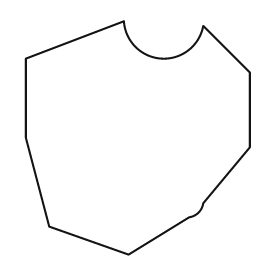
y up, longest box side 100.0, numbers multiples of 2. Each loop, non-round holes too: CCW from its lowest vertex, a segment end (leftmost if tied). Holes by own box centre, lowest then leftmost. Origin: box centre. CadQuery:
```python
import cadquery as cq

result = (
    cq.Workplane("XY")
    .moveTo(-4.0, -50.0)
    .lineTo(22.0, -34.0)
    .threePointArc((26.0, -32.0), (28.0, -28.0))
    .lineTo(48.0, -4.0)
    .lineTo(48.0, 28.0)
    .lineTo(28.0, 48.0)
    .threePointArc((10.0, 34.0), (-6.0, 50.0))
    .lineTo(-48.0, 34.0)
    .lineTo(-48.0, 0.0)
    .lineTo(-38.0, -38.0)
    .close()
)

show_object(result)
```